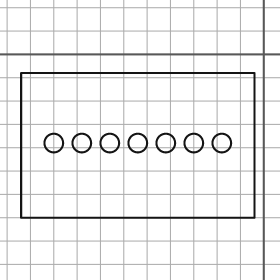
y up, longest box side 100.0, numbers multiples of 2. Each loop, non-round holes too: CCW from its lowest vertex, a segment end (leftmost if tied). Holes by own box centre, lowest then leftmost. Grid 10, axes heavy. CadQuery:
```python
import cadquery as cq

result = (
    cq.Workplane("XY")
    .moveTo(-104.0, -70.0)
    .lineTo(-4.0, -70.0)
    .lineTo(-4.0, -8.0)
    .lineTo(-104.0, -8.0)
    .close()
    .moveTo(-90.0, -38.0)
    .circle(4.0)
    .moveTo(-78.0, -38.0)
    .circle(4.0)
    .moveTo(-66.0, -38.0)
    .circle(4.0)
    .moveTo(-54.0, -38.0)
    .circle(4.0)
    .moveTo(-42.0, -38.0)
    .circle(4.0)
    .moveTo(-30.0, -38.0)
    .circle(4.0)
    .moveTo(-18.0, -38.0)
    .circle(4.0)
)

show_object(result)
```